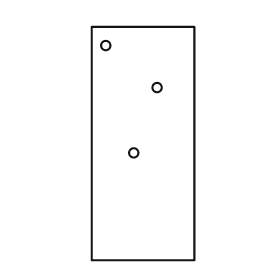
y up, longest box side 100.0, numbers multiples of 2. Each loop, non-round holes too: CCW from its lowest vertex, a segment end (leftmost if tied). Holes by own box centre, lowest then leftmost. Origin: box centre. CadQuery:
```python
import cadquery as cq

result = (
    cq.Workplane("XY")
    .moveTo(-22.0, -50.0)
    .lineTo(22.0, -50.0)
    .lineTo(22.0, 50.0)
    .lineTo(-22.0, 50.0)
    .close()
    .moveTo(-4.0, -4.0)
    .circle(2.0)
    .moveTo(6.0, 24.0)
    .circle(2.0)
    .moveTo(-16.0, 42.0)
    .circle(2.0)
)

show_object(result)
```